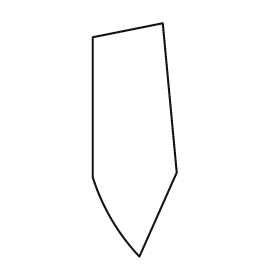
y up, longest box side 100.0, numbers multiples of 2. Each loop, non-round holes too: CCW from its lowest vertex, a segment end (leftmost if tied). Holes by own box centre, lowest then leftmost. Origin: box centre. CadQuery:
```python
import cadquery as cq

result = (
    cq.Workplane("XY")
    .moveTo(2.0, -50.0)
    .lineTo(18.0, -14.0)
    .lineTo(12.0, 50.0)
    .lineTo(-18.0, 44.0)
    .lineTo(-18.0, -16.0)
    .threePointArc((-10.0, -34.0), (2.0, -50.0))
    .close()
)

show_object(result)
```